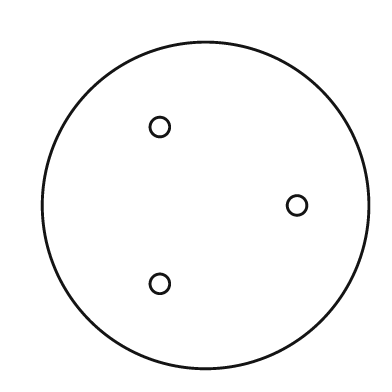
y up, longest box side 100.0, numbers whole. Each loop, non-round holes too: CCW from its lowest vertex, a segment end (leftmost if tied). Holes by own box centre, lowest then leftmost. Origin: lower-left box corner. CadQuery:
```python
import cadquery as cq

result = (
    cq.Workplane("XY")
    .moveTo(50.0, 50.0)
    .circle(50.0)
    .moveTo(36.0, 26.0)
    .circle(3.0)
    .moveTo(78.0, 50.0)
    .circle(3.0)
    .moveTo(36.0, 74.0)
    .circle(3.0)
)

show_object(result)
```